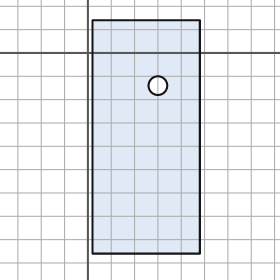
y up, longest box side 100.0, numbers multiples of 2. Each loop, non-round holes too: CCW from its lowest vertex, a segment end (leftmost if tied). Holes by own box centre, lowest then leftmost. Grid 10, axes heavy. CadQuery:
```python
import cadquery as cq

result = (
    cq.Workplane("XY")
    .moveTo(2.0, -86.0)
    .lineTo(48.0, -86.0)
    .lineTo(48.0, 14.0)
    .lineTo(2.0, 14.0)
    .close()
    .moveTo(30.0, -14.0)
    .circle(4.0)
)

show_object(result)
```